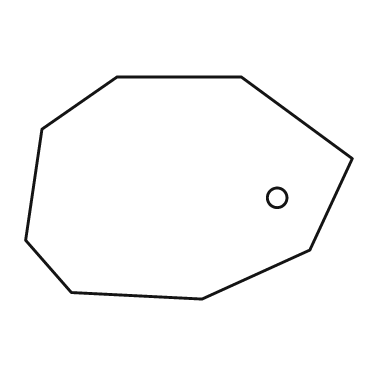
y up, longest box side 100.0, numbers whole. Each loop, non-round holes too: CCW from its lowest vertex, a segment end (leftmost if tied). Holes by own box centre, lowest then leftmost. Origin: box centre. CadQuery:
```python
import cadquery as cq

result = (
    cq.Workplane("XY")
    .moveTo(4.0, -34.0)
    .lineTo(37.0, -19.0)
    .lineTo(50.0, 9.0)
    .lineTo(16.0, 34.0)
    .lineTo(-22.0, 34.0)
    .lineTo(-45.0, 18.0)
    .lineTo(-50.0, -16.0)
    .lineTo(-36.0, -32.0)
    .close()
    .moveTo(27.0, -3.0)
    .circle(3.0)
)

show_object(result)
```